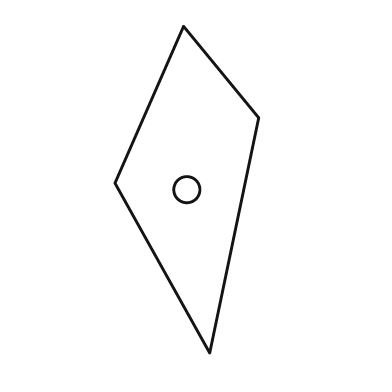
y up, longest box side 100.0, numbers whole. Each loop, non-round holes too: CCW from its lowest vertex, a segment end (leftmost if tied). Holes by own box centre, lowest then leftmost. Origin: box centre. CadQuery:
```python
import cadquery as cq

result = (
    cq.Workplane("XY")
    .moveTo(7.0, -50.0)
    .lineTo(22.0, 22.0)
    .lineTo(-1.0, 50.0)
    .lineTo(-22.0, 2.0)
    .close()
    .moveTo(0.0, 0.0)
    .circle(4.0)
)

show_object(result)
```